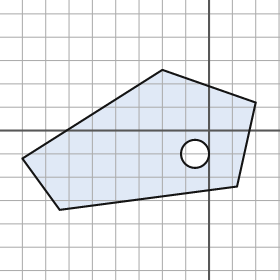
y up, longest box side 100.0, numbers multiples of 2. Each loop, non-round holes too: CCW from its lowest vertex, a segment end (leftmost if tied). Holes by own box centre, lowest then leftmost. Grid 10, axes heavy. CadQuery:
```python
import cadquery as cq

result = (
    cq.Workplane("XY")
    .moveTo(-64.0, -34.0)
    .lineTo(12.0, -24.0)
    .lineTo(20.0, 12.0)
    .lineTo(-20.0, 26.0)
    .lineTo(-80.0, -12.0)
    .close()
    .moveTo(-6.0, -10.0)
    .circle(6.0)
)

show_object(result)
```